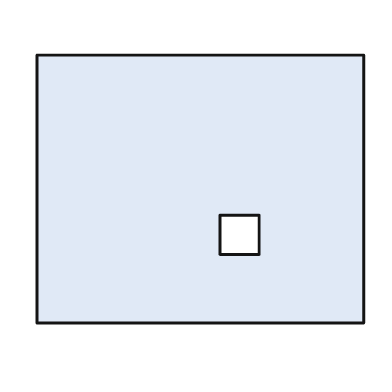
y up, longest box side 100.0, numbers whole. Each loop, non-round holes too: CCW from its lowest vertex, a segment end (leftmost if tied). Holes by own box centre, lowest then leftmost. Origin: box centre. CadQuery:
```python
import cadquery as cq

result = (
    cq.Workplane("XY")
    .moveTo(-50.0, -41.0)
    .lineTo(50.0, -41.0)
    .lineTo(50.0, 41.0)
    .lineTo(-50.0, 41.0)
    .close()
    .moveTo(6.0, -20.0)
    .lineTo(18.0, -20.0)
    .lineTo(18.0, -8.0)
    .lineTo(6.0, -8.0)
    .close()
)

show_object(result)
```